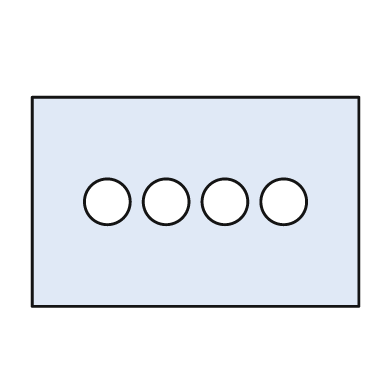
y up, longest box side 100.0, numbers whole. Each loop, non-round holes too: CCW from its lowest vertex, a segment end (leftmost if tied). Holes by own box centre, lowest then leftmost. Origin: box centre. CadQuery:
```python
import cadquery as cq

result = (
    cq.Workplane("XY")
    .moveTo(-50.0, -32.0)
    .lineTo(50.0, -32.0)
    .lineTo(50.0, 32.0)
    .lineTo(-50.0, 32.0)
    .close()
    .moveTo(-27.0, 0.0)
    .circle(7.0)
    .moveTo(-9.0, 0.0)
    .circle(7.0)
    .moveTo(9.0, 0.0)
    .circle(7.0)
    .moveTo(27.0, 0.0)
    .circle(7.0)
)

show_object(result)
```